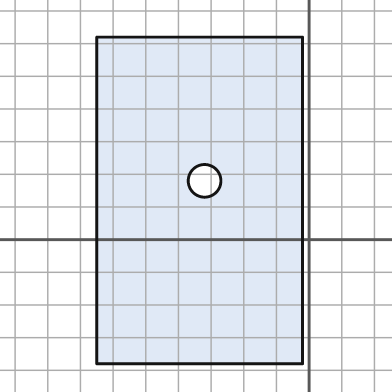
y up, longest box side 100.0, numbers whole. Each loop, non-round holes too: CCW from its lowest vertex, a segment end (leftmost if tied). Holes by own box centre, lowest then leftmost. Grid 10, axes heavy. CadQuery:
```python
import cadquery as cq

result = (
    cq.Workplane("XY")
    .moveTo(-65.0, -38.0)
    .lineTo(-2.0, -38.0)
    .lineTo(-2.0, 62.0)
    .lineTo(-65.0, 62.0)
    .close()
    .moveTo(-32.0, 18.0)
    .circle(5.0)
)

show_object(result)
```